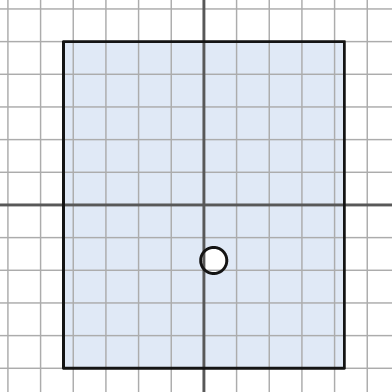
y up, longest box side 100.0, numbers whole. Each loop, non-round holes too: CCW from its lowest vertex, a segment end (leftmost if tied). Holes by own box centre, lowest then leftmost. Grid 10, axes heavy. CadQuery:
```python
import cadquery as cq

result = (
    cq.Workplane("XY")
    .moveTo(-43.0, -50.0)
    .lineTo(43.0, -50.0)
    .lineTo(43.0, 50.0)
    .lineTo(-43.0, 50.0)
    .close()
    .moveTo(3.0, -17.0)
    .circle(4.0)
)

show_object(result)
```